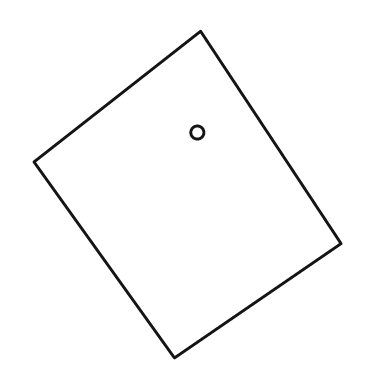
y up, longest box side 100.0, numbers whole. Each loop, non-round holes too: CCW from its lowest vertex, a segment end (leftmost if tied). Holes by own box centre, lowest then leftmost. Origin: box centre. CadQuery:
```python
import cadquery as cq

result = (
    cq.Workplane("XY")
    .moveTo(-4.0, -50.0)
    .lineTo(47.0, -15.0)
    .lineTo(4.0, 50.0)
    .lineTo(-47.0, 10.0)
    .close()
    .moveTo(3.0, 19.0)
    .circle(2.0)
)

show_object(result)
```